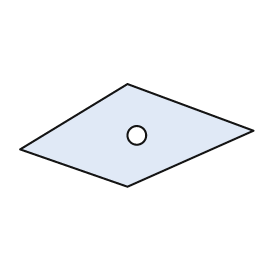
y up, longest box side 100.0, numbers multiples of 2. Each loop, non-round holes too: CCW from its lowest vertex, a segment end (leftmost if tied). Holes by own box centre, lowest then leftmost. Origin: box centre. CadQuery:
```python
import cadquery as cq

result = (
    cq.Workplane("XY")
    .moveTo(-4.0, -22.0)
    .lineTo(50.0, 2.0)
    .lineTo(-4.0, 22.0)
    .lineTo(-50.0, -6.0)
    .close()
    .moveTo(0.0, 0.0)
    .circle(4.0)
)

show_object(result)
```